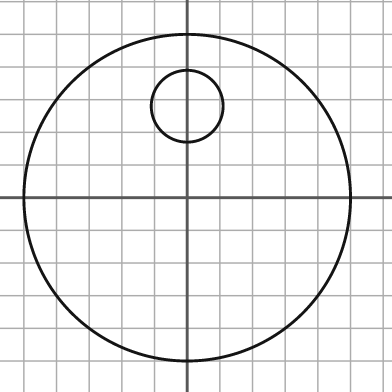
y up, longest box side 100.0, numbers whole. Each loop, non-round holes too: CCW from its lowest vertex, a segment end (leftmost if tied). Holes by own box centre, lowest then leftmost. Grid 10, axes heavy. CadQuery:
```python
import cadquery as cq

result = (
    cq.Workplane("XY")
    .moveTo(0.0, 0.0)
    .circle(50.0)
    .moveTo(0.0, 28.0)
    .circle(11.0)
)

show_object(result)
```